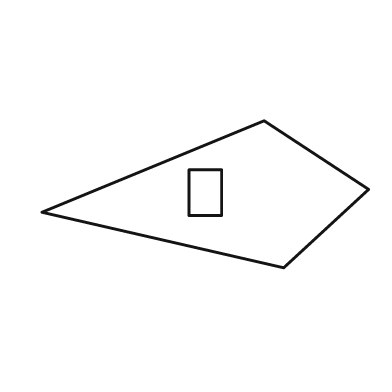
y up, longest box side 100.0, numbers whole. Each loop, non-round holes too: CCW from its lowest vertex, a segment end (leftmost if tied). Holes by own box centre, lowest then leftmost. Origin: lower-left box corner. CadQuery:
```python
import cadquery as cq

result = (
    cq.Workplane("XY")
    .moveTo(74.0, 0.0)
    .lineTo(100.0, 24.0)
    .lineTo(68.0, 45.0)
    .lineTo(0.0, 17.0)
    .close()
    .moveTo(45.0, 16.0)
    .lineTo(55.0, 16.0)
    .lineTo(55.0, 30.0)
    .lineTo(45.0, 30.0)
    .close()
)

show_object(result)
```